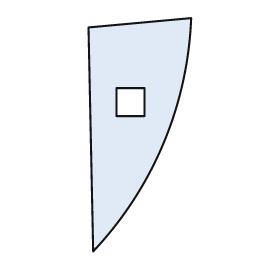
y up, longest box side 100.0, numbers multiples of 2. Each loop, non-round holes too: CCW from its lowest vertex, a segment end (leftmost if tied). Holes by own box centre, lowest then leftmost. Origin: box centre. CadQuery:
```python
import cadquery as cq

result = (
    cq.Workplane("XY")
    .moveTo(-20.0, -50.0)
    .threePointArc((10.0, -4.0), (22.0, 50.0))
    .lineTo(-22.0, 46.0)
    .close()
    .moveTo(-10.0, 8.0)
    .lineTo(2.0, 8.0)
    .lineTo(2.0, 20.0)
    .lineTo(-10.0, 20.0)
    .close()
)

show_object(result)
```